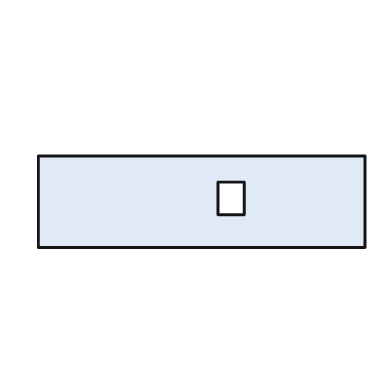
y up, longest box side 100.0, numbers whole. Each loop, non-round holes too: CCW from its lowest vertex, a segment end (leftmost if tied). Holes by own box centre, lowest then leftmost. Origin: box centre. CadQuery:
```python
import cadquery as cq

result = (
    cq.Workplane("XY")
    .moveTo(-50.0, -14.0)
    .lineTo(50.0, -14.0)
    .lineTo(50.0, 14.0)
    .lineTo(-50.0, 14.0)
    .close()
    .moveTo(5.0, -4.0)
    .lineTo(13.0, -4.0)
    .lineTo(13.0, 6.0)
    .lineTo(5.0, 6.0)
    .close()
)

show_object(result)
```